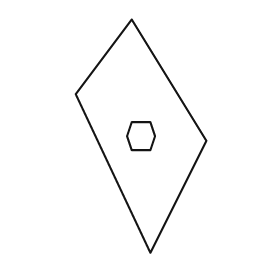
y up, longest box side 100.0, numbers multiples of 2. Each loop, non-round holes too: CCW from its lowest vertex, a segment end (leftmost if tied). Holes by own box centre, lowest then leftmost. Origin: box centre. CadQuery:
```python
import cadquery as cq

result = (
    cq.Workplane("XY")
    .moveTo(4.0, -50.0)
    .lineTo(28.0, -2.0)
    .lineTo(-4.0, 50.0)
    .lineTo(-28.0, 18.0)
    .close()
    .moveTo(-4.0, -6.0)
    .lineTo(4.0, -6.0)
    .lineTo(6.0, 0.0)
    .lineTo(4.0, 6.0)
    .lineTo(-4.0, 6.0)
    .lineTo(-6.0, 0.0)
    .close()
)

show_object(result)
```